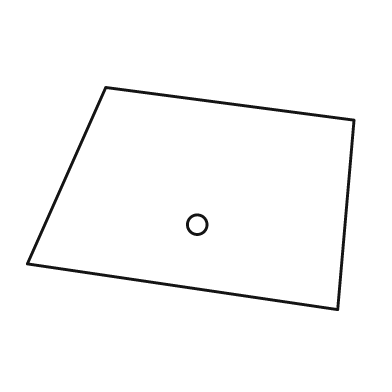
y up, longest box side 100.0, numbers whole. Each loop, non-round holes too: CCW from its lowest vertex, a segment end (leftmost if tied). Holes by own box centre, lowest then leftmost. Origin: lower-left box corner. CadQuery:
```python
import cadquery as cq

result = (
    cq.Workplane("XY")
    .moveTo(95.0, 0.0)
    .lineTo(100.0, 58.0)
    .lineTo(24.0, 68.0)
    .lineTo(0.0, 14.0)
    .close()
    .moveTo(52.0, 26.0)
    .circle(3.0)
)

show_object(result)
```